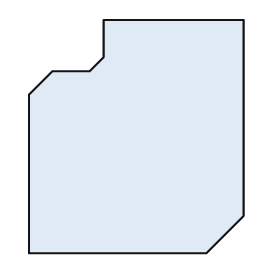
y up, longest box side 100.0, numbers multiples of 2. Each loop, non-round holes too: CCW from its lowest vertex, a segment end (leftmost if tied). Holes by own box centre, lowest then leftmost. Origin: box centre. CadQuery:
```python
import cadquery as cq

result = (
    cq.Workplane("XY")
    .moveTo(-46.0, -50.0)
    .lineTo(30.0, -50.0)
    .lineTo(46.0, -34.0)
    .lineTo(46.0, 50.0)
    .lineTo(-14.0, 50.0)
    .lineTo(-14.0, 34.0)
    .lineTo(-20.0, 28.0)
    .lineTo(-36.0, 28.0)
    .lineTo(-46.0, 18.0)
    .close()
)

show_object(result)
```